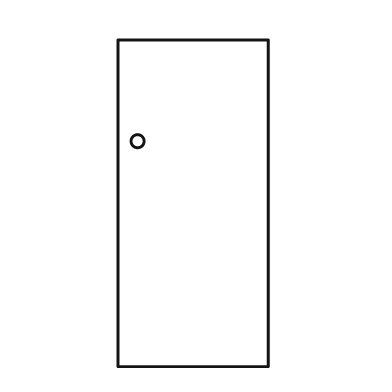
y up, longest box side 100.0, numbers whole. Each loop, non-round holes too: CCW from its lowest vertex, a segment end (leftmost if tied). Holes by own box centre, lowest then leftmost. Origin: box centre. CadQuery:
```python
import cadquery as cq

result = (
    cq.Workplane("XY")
    .moveTo(-23.0, -50.0)
    .lineTo(23.0, -50.0)
    .lineTo(23.0, 50.0)
    .lineTo(-23.0, 50.0)
    .close()
    .moveTo(-17.0, 19.0)
    .circle(2.0)
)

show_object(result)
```